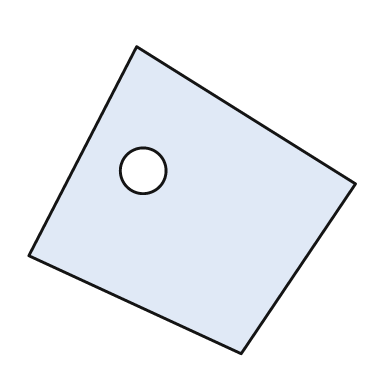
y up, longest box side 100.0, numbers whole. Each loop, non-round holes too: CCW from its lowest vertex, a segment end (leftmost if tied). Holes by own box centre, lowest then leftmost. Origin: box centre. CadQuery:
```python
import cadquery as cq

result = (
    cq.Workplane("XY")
    .moveTo(15.0, -47.0)
    .lineTo(50.0, 5.0)
    .lineTo(-17.0, 47.0)
    .lineTo(-50.0, -17.0)
    .close()
    .moveTo(-15.0, 9.0)
    .circle(7.0)
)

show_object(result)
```